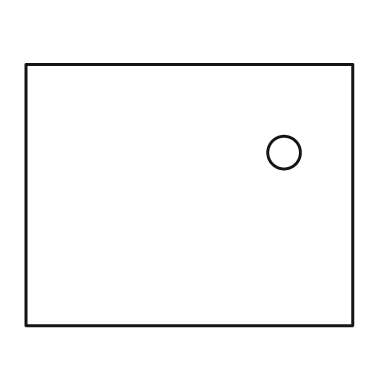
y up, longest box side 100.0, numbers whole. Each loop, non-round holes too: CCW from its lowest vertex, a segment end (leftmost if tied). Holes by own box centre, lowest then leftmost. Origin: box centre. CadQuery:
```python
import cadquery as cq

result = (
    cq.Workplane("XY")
    .moveTo(-50.0, -40.0)
    .lineTo(50.0, -40.0)
    .lineTo(50.0, 40.0)
    .lineTo(-50.0, 40.0)
    .close()
    .moveTo(29.0, 13.0)
    .circle(5.0)
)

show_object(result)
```